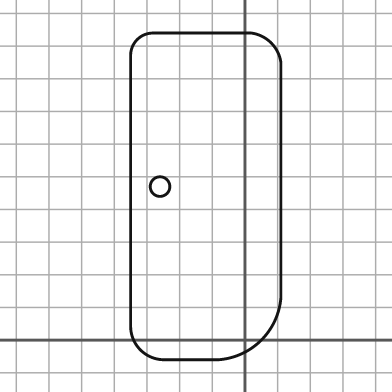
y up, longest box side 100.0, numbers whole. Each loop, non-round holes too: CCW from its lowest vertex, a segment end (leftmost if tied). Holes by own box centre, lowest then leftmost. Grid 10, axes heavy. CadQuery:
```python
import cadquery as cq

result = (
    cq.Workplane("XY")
    .moveTo(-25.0, -6.0)
    .lineTo(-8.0, -6.0)
    .threePointArc((5.0, 0.0), (11.0, 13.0))
    .lineTo(11.0, 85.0)
    .threePointArc((8.0, 91.0), (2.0, 94.0))
    .lineTo(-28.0, 94.0)
    .threePointArc((-33.0, 92.0), (-35.0, 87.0))
    .lineTo(-35.0, 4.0)
    .threePointArc((-32.0, -3.0), (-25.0, -6.0))
    .close()
    .moveTo(-26.0, 47.0)
    .circle(3.0)
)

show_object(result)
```